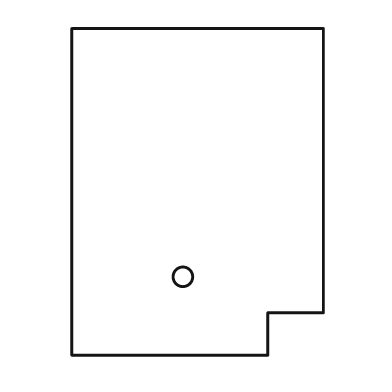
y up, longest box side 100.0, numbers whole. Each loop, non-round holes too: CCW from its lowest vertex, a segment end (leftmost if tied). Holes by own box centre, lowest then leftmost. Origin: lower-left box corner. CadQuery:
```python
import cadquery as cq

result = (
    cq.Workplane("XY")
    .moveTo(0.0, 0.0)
    .lineTo(60.0, 0.0)
    .lineTo(60.0, 13.0)
    .lineTo(77.0, 13.0)
    .lineTo(77.0, 100.0)
    .lineTo(0.0, 100.0)
    .close()
    .moveTo(34.0, 24.0)
    .circle(3.0)
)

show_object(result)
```